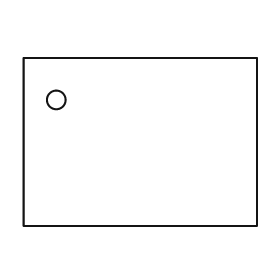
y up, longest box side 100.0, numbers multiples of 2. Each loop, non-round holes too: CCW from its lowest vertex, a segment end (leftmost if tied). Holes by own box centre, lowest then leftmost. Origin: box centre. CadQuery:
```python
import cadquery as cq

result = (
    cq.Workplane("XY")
    .moveTo(-50.0, -36.0)
    .lineTo(50.0, -36.0)
    .lineTo(50.0, 36.0)
    .lineTo(-50.0, 36.0)
    .close()
    .moveTo(-36.0, 18.0)
    .circle(4.0)
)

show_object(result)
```